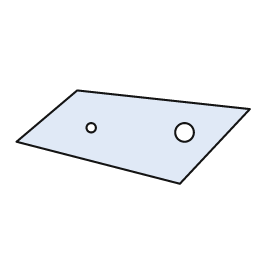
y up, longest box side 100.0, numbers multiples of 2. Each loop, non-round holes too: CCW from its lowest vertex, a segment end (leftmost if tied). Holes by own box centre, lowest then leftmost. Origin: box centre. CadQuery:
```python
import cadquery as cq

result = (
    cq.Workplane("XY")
    .moveTo(20.0, -20.0)
    .lineTo(50.0, 12.0)
    .lineTo(-24.0, 20.0)
    .lineTo(-50.0, -2.0)
    .close()
    .moveTo(22.0, 2.0)
    .circle(4.0)
    .moveTo(-18.0, 4.0)
    .circle(2.0)
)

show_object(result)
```